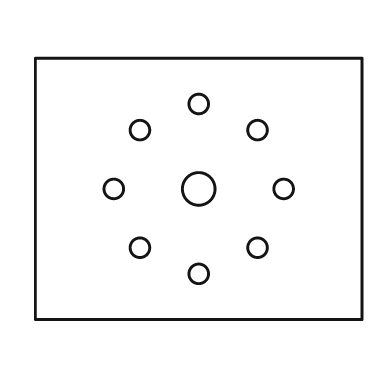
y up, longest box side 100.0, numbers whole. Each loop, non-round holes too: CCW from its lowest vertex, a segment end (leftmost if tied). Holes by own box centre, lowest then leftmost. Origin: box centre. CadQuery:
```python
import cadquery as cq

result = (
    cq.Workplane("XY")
    .moveTo(-50.0, -40.0)
    .lineTo(50.0, -40.0)
    .lineTo(50.0, 40.0)
    .lineTo(-50.0, 40.0)
    .close()
    .moveTo(0.0, -26.0)
    .circle(3.0)
    .moveTo(-18.0, -18.0)
    .circle(3.0)
    .moveTo(18.0, -18.0)
    .circle(3.0)
    .moveTo(-26.0, 0.0)
    .circle(3.0)
    .moveTo(0.0, 0.0)
    .circle(5.0)
    .moveTo(26.0, 0.0)
    .circle(3.0)
    .moveTo(-18.0, 18.0)
    .circle(3.0)
    .moveTo(18.0, 18.0)
    .circle(3.0)
    .moveTo(0.0, 26.0)
    .circle(3.0)
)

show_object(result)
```